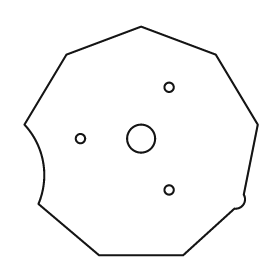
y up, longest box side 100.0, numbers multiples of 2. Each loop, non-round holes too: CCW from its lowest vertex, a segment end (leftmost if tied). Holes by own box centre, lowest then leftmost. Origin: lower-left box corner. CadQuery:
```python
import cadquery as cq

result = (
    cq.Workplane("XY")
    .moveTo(32.0, 0.0)
    .lineTo(68.0, 0.0)
    .lineTo(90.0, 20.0)
    .threePointArc((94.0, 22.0), (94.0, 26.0))
    .lineTo(100.0, 56.0)
    .lineTo(82.0, 86.0)
    .lineTo(50.0, 98.0)
    .lineTo(18.0, 86.0)
    .lineTo(0.0, 56.0)
    .threePointArc((8.0, 40.0), (6.0, 22.0))
    .close()
    .moveTo(62.0, 28.0)
    .circle(2.0)
    .moveTo(24.0, 50.0)
    .circle(2.0)
    .moveTo(50.0, 50.0)
    .circle(6.0)
    .moveTo(62.0, 72.0)
    .circle(2.0)
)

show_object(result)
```